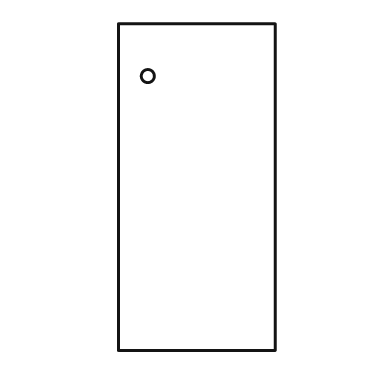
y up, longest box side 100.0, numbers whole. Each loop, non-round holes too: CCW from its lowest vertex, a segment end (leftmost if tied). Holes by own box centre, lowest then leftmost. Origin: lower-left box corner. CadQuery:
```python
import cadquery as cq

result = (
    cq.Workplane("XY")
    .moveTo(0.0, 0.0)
    .lineTo(48.0, 0.0)
    .lineTo(48.0, 100.0)
    .lineTo(0.0, 100.0)
    .close()
    .moveTo(9.0, 84.0)
    .circle(2.0)
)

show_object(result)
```